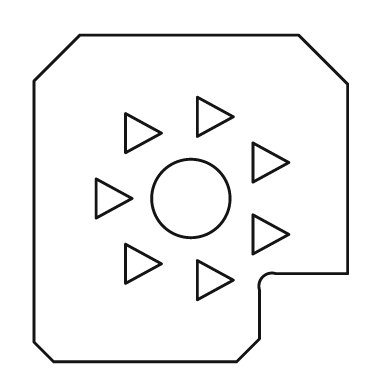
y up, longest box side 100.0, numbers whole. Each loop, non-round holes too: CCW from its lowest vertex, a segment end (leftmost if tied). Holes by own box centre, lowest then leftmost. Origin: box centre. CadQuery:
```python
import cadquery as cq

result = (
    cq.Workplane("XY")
    .moveTo(-42.0, -50.0)
    .lineTo(14.0, -50.0)
    .lineTo(21.0, -43.0)
    .lineTo(21.0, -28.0)
    .threePointArc((22.0, -24.0), (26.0, -23.0))
    .lineTo(48.0, -23.0)
    .lineTo(48.0, 35.0)
    .lineTo(33.0, 50.0)
    .lineTo(-34.0, 50.0)
    .lineTo(-48.0, 36.0)
    .lineTo(-48.0, -44.0)
    .close()
    .moveTo(2.0, -31.0)
    .lineTo(13.0, -25.0)
    .lineTo(2.0, -19.0)
    .close()
    .moveTo(-20.0, -26.0)
    .lineTo(-9.0, -20.0)
    .lineTo(-20.0, -14.0)
    .close()
    .moveTo(19.0, -17.0)
    .lineTo(30.0, -11.0)
    .lineTo(19.0, -5.0)
    .close()
    .moveTo(-29.0, -6.0)
    .lineTo(-18.0, 0.0)
    .lineTo(-29.0, 6.0)
    .close()
    .moveTo(0.0, 0.0)
    .circle(12.0)
    .moveTo(19.0, 5.0)
    .lineTo(30.0, 11.0)
    .lineTo(19.0, 17.0)
    .close()
    .moveTo(-20.0, 14.0)
    .lineTo(-9.0, 20.0)
    .lineTo(-20.0, 26.0)
    .close()
    .moveTo(2.0, 19.0)
    .lineTo(13.0, 25.0)
    .lineTo(2.0, 31.0)
    .close()
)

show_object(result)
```